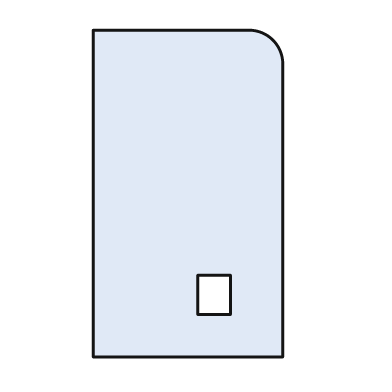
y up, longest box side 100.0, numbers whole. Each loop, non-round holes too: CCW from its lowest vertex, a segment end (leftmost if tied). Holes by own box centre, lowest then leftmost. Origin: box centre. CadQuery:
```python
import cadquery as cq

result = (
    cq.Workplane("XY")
    .moveTo(-29.0, -50.0)
    .lineTo(29.0, -50.0)
    .lineTo(29.0, 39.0)
    .threePointArc((26.0, 47.0), (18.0, 50.0))
    .lineTo(-29.0, 50.0)
    .close()
    .moveTo(3.0, -37.0)
    .lineTo(13.0, -37.0)
    .lineTo(13.0, -25.0)
    .lineTo(3.0, -25.0)
    .close()
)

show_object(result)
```